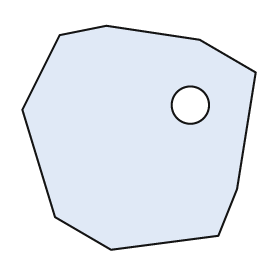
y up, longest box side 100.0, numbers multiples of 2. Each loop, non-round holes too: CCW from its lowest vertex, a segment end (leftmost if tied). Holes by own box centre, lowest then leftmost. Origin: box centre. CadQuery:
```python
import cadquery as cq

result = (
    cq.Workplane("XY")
    .moveTo(-12.0, -48.0)
    .lineTo(34.0, -42.0)
    .lineTo(42.0, -22.0)
    .lineTo(50.0, 28.0)
    .lineTo(26.0, 42.0)
    .lineTo(-14.0, 48.0)
    .lineTo(-34.0, 44.0)
    .lineTo(-50.0, 12.0)
    .lineTo(-36.0, -34.0)
    .close()
    .moveTo(22.0, 14.0)
    .circle(8.0)
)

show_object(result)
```